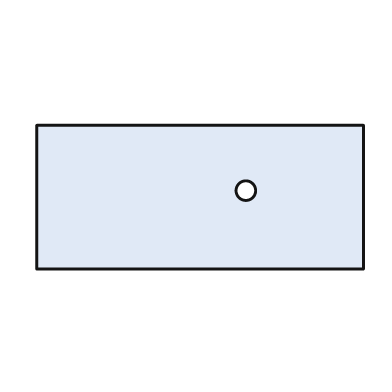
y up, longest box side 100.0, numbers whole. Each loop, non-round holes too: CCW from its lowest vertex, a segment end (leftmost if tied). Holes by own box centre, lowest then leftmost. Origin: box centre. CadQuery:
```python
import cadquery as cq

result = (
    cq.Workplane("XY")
    .moveTo(-50.0, -22.0)
    .lineTo(50.0, -22.0)
    .lineTo(50.0, 22.0)
    .lineTo(-50.0, 22.0)
    .close()
    .moveTo(14.0, 2.0)
    .circle(3.0)
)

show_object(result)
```